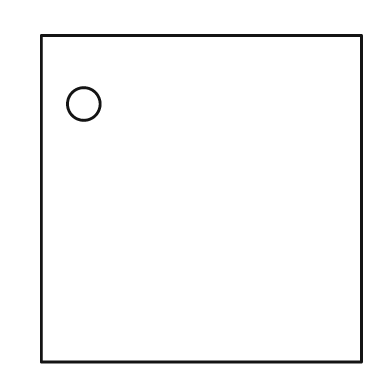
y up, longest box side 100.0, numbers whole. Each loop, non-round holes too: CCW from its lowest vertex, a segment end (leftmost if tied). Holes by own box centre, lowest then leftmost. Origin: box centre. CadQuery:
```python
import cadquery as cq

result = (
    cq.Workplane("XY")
    .moveTo(-49.0, -50.0)
    .lineTo(49.0, -50.0)
    .lineTo(49.0, 50.0)
    .lineTo(-49.0, 50.0)
    .close()
    .moveTo(-36.0, 29.0)
    .circle(5.0)
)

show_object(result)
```